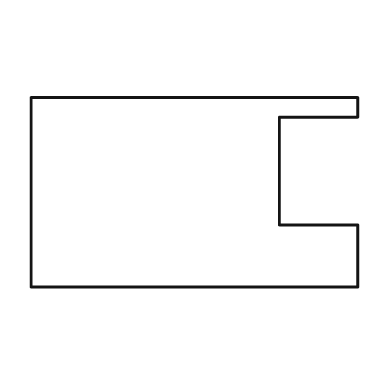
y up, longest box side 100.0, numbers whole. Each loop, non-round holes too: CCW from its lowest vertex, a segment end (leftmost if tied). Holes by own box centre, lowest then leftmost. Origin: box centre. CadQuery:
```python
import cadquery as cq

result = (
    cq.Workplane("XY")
    .moveTo(-50.0, -29.0)
    .lineTo(50.0, -29.0)
    .lineTo(50.0, -10.0)
    .lineTo(26.0, -10.0)
    .lineTo(26.0, 23.0)
    .lineTo(50.0, 23.0)
    .lineTo(50.0, 29.0)
    .lineTo(-50.0, 29.0)
    .close()
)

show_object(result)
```